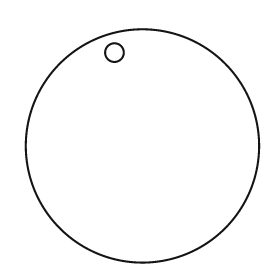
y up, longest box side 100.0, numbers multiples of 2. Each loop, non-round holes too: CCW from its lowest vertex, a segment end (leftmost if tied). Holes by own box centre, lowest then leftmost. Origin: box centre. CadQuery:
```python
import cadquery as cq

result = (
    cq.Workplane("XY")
    .moveTo(0.0, 0.0)
    .circle(50.0)
    .moveTo(-12.0, 40.0)
    .circle(4.0)
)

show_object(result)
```